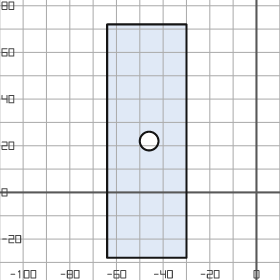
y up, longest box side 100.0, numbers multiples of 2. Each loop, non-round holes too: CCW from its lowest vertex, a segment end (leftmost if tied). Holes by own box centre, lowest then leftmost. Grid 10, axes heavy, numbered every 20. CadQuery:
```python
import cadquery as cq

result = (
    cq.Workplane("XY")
    .moveTo(-64.0, -28.0)
    .lineTo(-30.0, -28.0)
    .lineTo(-30.0, 72.0)
    .lineTo(-64.0, 72.0)
    .close()
    .moveTo(-46.0, 22.0)
    .circle(4.0)
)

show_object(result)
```